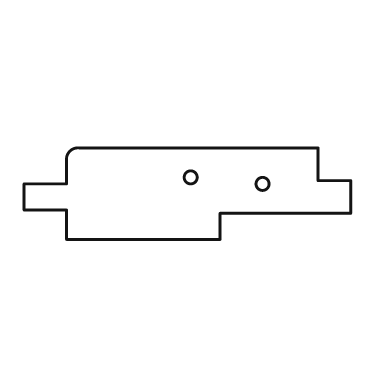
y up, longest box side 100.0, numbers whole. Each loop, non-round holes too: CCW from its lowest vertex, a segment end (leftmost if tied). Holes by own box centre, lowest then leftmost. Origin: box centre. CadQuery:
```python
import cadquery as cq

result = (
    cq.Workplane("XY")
    .moveTo(-37.0, -14.0)
    .lineTo(10.0, -14.0)
    .lineTo(10.0, -6.0)
    .lineTo(50.0, -6.0)
    .lineTo(50.0, 4.0)
    .lineTo(40.0, 4.0)
    .lineTo(40.0, 14.0)
    .lineTo(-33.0, 14.0)
    .threePointArc((-36.0, 13.0), (-37.0, 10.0))
    .lineTo(-37.0, 3.0)
    .lineTo(-50.0, 3.0)
    .lineTo(-50.0, -5.0)
    .lineTo(-37.0, -5.0)
    .close()
    .moveTo(23.0, 3.0)
    .circle(2.0)
    .moveTo(1.0, 5.0)
    .circle(2.0)
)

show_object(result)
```